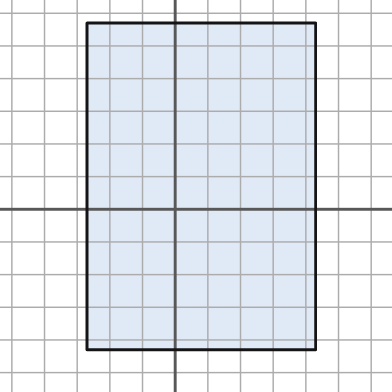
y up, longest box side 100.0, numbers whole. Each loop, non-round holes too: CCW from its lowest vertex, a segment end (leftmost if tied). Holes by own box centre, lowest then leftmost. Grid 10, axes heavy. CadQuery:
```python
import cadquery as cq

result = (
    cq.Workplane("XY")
    .moveTo(-27.0, -43.0)
    .lineTo(43.0, -43.0)
    .lineTo(43.0, 57.0)
    .lineTo(-27.0, 57.0)
    .close()
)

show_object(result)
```